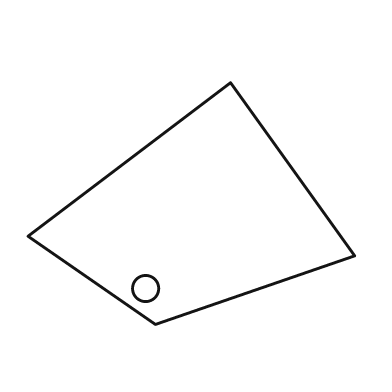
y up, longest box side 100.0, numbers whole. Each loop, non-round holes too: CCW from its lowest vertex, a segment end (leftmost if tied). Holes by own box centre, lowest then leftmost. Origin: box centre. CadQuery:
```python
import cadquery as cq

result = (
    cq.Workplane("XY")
    .moveTo(-11.0, -37.0)
    .lineTo(50.0, -16.0)
    .lineTo(12.0, 37.0)
    .lineTo(-50.0, -10.0)
    .close()
    .moveTo(-14.0, -26.0)
    .circle(4.0)
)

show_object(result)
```